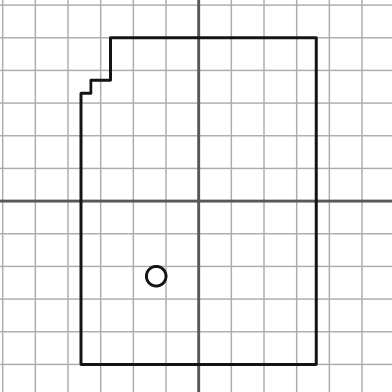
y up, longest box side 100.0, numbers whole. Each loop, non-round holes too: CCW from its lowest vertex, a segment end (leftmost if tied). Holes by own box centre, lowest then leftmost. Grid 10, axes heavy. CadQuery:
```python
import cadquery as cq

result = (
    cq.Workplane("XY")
    .moveTo(-36.0, -50.0)
    .lineTo(36.0, -50.0)
    .lineTo(36.0, 50.0)
    .lineTo(-27.0, 50.0)
    .lineTo(-27.0, 37.0)
    .lineTo(-33.0, 37.0)
    .lineTo(-33.0, 33.0)
    .lineTo(-36.0, 33.0)
    .close()
    .moveTo(-13.0, -23.0)
    .circle(3.0)
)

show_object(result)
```